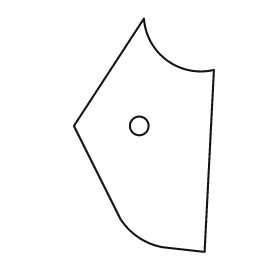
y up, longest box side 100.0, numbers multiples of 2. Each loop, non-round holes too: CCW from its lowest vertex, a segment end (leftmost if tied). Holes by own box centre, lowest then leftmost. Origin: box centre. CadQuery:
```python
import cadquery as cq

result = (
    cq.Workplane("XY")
    .moveTo(26.0, -50.0)
    .lineTo(30.0, 28.0)
    .threePointArc((10.0, 32.0), (0.0, 50.0))
    .lineTo(-30.0, 4.0)
    .lineTo(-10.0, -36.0)
    .threePointArc((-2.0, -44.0), (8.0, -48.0))
    .close()
    .moveTo(-2.0, 4.0)
    .circle(4.0)
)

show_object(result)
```